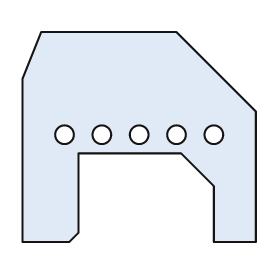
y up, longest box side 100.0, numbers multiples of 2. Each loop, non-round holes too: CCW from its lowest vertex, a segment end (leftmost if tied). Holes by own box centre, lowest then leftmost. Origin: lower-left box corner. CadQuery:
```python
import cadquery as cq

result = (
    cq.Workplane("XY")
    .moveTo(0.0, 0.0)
    .lineTo(20.0, 0.0)
    .lineTo(24.0, 4.0)
    .lineTo(24.0, 38.0)
    .lineTo(68.0, 38.0)
    .lineTo(82.0, 24.0)
    .lineTo(82.0, 0.0)
    .lineTo(100.0, 0.0)
    .lineTo(100.0, 56.0)
    .lineTo(66.0, 90.0)
    .lineTo(8.0, 90.0)
    .lineTo(0.0, 70.0)
    .close()
    .moveTo(18.0, 46.0)
    .circle(4.0)
    .moveTo(34.0, 46.0)
    .circle(4.0)
    .moveTo(50.0, 46.0)
    .circle(4.0)
    .moveTo(66.0, 46.0)
    .circle(4.0)
    .moveTo(82.0, 46.0)
    .circle(4.0)
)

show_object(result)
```